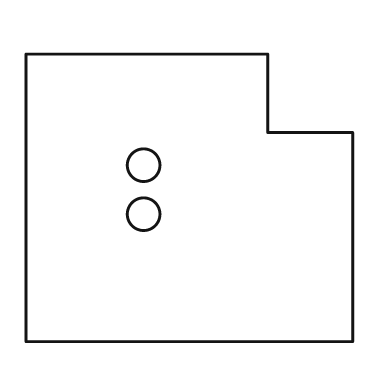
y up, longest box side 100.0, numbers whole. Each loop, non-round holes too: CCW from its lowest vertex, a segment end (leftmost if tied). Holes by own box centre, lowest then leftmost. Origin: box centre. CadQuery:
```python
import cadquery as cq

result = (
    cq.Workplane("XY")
    .moveTo(-50.0, -44.0)
    .lineTo(50.0, -44.0)
    .lineTo(50.0, 20.0)
    .lineTo(24.0, 20.0)
    .lineTo(24.0, 44.0)
    .lineTo(-50.0, 44.0)
    .close()
    .moveTo(-14.0, -5.0)
    .circle(5.0)
    .moveTo(-14.0, 10.0)
    .circle(5.0)
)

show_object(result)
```